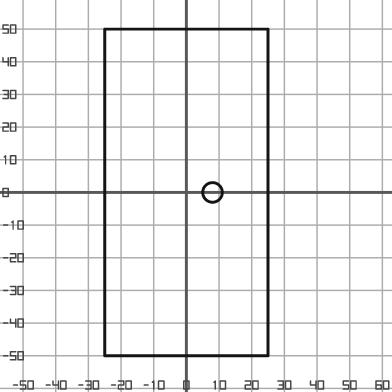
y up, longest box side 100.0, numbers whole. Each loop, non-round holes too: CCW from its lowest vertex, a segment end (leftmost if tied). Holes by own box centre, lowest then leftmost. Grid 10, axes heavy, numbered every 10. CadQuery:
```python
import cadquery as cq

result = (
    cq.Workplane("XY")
    .moveTo(-25.0, -50.0)
    .lineTo(25.0, -50.0)
    .lineTo(25.0, 50.0)
    .lineTo(-25.0, 50.0)
    .close()
    .moveTo(8.0, 0.0)
    .circle(3.0)
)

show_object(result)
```